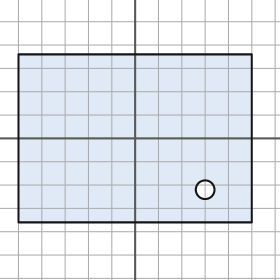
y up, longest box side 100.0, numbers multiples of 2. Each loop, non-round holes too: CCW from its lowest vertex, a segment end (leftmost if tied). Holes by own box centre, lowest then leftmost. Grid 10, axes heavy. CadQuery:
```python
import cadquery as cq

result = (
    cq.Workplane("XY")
    .moveTo(-50.0, -36.0)
    .lineTo(50.0, -36.0)
    .lineTo(50.0, 36.0)
    .lineTo(-50.0, 36.0)
    .close()
    .moveTo(30.0, -22.0)
    .circle(4.0)
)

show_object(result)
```